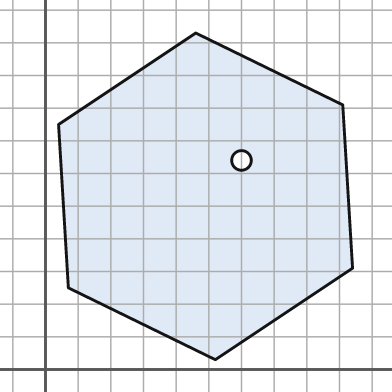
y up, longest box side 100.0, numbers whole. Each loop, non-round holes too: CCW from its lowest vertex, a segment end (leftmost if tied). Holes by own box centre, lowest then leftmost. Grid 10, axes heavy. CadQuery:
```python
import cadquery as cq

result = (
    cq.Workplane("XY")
    .moveTo(52.0, 3.0)
    .lineTo(94.0, 31.0)
    .lineTo(91.0, 81.0)
    .lineTo(46.0, 103.0)
    .lineTo(4.0, 75.0)
    .lineTo(7.0, 25.0)
    .close()
    .moveTo(60.0, 64.0)
    .circle(3.0)
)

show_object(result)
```